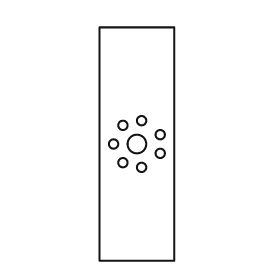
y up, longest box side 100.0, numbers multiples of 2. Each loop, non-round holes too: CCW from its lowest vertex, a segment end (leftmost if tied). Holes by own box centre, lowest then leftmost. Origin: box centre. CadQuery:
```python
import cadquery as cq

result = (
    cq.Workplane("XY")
    .moveTo(-16.0, -50.0)
    .lineTo(16.0, -50.0)
    .lineTo(16.0, 50.0)
    .lineTo(-16.0, 50.0)
    .close()
    .moveTo(2.0, -10.0)
    .circle(2.0)
    .moveTo(-6.0, -8.0)
    .circle(2.0)
    .moveTo(10.0, -4.0)
    .circle(2.0)
    .moveTo(-10.0, 0.0)
    .circle(2.0)
    .moveTo(0.0, 0.0)
    .circle(4.0)
    .moveTo(10.0, 4.0)
    .circle(2.0)
    .moveTo(-6.0, 8.0)
    .circle(2.0)
    .moveTo(2.0, 10.0)
    .circle(2.0)
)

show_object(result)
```